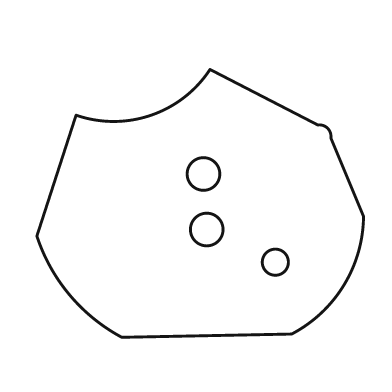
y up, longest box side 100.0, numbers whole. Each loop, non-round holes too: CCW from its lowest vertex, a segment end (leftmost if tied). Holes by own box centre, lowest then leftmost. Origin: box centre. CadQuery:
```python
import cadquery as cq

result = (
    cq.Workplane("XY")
    .moveTo(-24.0, -41.0)
    .lineTo(28.0, -40.0)
    .threePointArc((44.0, -25.0), (50.0, -4.0))
    .lineTo(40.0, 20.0)
    .threePointArc((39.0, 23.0), (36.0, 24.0))
    .lineTo(3.0, 41.0)
    .threePointArc((-15.0, 27.0), (-38.0, 27.0))
    .lineTo(-50.0, -10.0)
    .threePointArc((-40.0, -28.0), (-24.0, -41.0))
    .close()
    .moveTo(23.0, -18.0)
    .circle(4.0)
    .moveTo(2.0, -8.0)
    .circle(5.0)
    .moveTo(1.0, 9.0)
    .circle(5.0)
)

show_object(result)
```